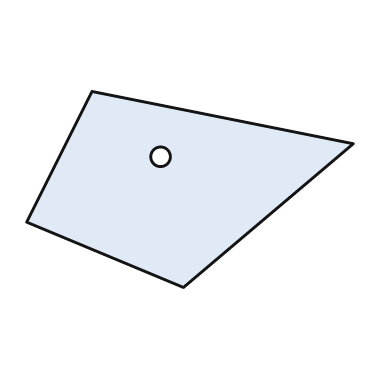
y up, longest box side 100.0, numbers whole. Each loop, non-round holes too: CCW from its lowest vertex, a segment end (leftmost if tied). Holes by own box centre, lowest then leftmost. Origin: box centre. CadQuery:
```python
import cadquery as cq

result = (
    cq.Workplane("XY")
    .moveTo(-2.0, -30.0)
    .lineTo(50.0, 14.0)
    .lineTo(-30.0, 30.0)
    .lineTo(-50.0, -10.0)
    .close()
    .moveTo(-9.0, 10.0)
    .circle(3.0)
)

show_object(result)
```